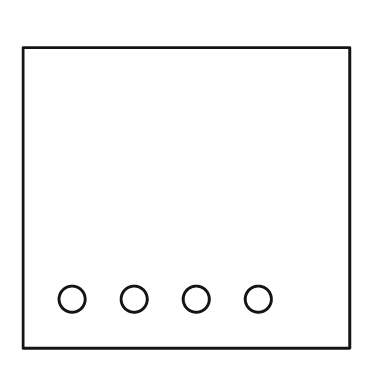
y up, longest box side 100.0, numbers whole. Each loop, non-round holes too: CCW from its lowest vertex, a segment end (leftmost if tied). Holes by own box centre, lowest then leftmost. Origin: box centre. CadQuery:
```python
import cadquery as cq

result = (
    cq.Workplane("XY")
    .moveTo(-50.0, -46.0)
    .lineTo(50.0, -46.0)
    .lineTo(50.0, 46.0)
    .lineTo(-50.0, 46.0)
    .close()
    .moveTo(-35.0, -31.0)
    .circle(4.0)
    .moveTo(-16.0, -31.0)
    .circle(4.0)
    .moveTo(3.0, -31.0)
    .circle(4.0)
    .moveTo(22.0, -31.0)
    .circle(4.0)
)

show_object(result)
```